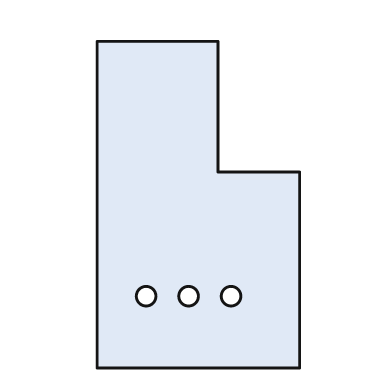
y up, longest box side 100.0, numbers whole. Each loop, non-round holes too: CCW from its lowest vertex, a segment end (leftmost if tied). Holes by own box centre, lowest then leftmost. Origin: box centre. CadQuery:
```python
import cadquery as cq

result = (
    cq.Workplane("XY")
    .moveTo(-31.0, -50.0)
    .lineTo(31.0, -50.0)
    .lineTo(31.0, 10.0)
    .lineTo(6.0, 10.0)
    .lineTo(6.0, 50.0)
    .lineTo(-31.0, 50.0)
    .close()
    .moveTo(-16.0, -28.0)
    .circle(3.0)
    .moveTo(-3.0, -28.0)
    .circle(3.0)
    .moveTo(10.0, -28.0)
    .circle(3.0)
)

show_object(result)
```